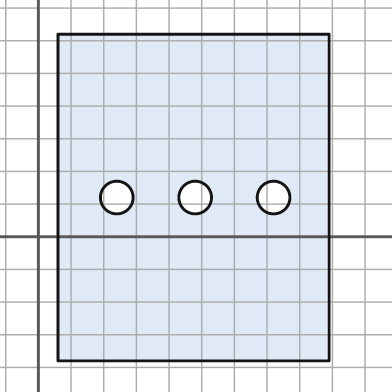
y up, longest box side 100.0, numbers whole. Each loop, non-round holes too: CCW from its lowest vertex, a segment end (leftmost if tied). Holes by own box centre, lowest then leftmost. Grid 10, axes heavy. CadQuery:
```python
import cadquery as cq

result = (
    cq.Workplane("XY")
    .moveTo(6.0, -38.0)
    .lineTo(89.0, -38.0)
    .lineTo(89.0, 62.0)
    .lineTo(6.0, 62.0)
    .close()
    .moveTo(24.0, 12.0)
    .circle(5.0)
    .moveTo(48.0, 12.0)
    .circle(5.0)
    .moveTo(72.0, 12.0)
    .circle(5.0)
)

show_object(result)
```